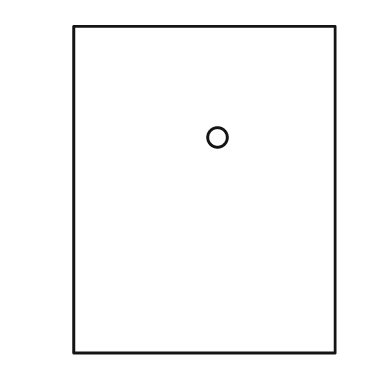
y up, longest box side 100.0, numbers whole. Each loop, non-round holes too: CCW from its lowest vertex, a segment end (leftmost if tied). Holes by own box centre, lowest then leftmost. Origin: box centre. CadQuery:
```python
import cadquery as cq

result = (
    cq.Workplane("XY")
    .moveTo(-40.0, -50.0)
    .lineTo(40.0, -50.0)
    .lineTo(40.0, 50.0)
    .lineTo(-40.0, 50.0)
    .close()
    .moveTo(4.0, 16.0)
    .circle(3.0)
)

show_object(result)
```